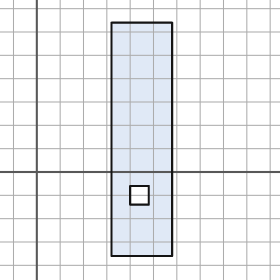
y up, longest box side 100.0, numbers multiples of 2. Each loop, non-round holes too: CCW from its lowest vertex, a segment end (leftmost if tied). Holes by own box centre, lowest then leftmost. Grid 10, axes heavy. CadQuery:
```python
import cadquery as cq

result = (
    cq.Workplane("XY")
    .moveTo(32.0, -36.0)
    .lineTo(58.0, -36.0)
    .lineTo(58.0, 64.0)
    .lineTo(32.0, 64.0)
    .close()
    .moveTo(40.0, -14.0)
    .lineTo(48.0, -14.0)
    .lineTo(48.0, -6.0)
    .lineTo(40.0, -6.0)
    .close()
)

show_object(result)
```